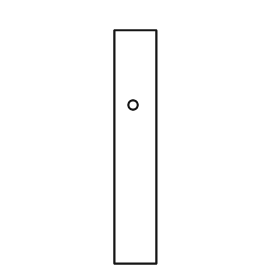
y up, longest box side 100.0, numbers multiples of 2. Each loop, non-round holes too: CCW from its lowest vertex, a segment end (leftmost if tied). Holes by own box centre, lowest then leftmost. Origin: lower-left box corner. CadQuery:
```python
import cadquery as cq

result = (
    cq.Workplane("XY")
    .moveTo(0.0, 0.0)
    .lineTo(18.0, 0.0)
    .lineTo(18.0, 100.0)
    .lineTo(0.0, 100.0)
    .close()
    .moveTo(8.0, 68.0)
    .circle(2.0)
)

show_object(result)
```